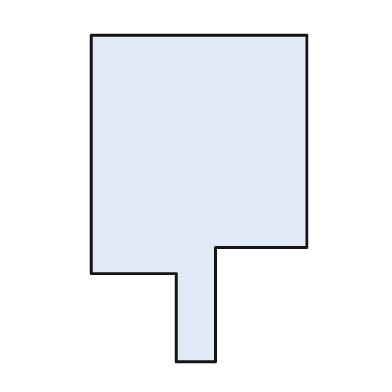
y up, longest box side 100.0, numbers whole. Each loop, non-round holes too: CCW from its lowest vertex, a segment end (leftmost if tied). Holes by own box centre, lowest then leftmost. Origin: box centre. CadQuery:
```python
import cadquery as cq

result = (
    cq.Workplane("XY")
    .moveTo(-7.0, -50.0)
    .lineTo(5.0, -50.0)
    .lineTo(5.0, -15.0)
    .lineTo(33.0, -15.0)
    .lineTo(33.0, 50.0)
    .lineTo(-33.0, 50.0)
    .lineTo(-33.0, -23.0)
    .lineTo(-7.0, -23.0)
    .close()
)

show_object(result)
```